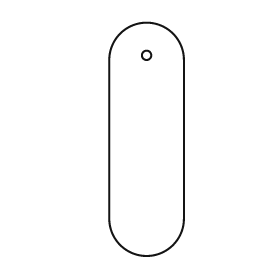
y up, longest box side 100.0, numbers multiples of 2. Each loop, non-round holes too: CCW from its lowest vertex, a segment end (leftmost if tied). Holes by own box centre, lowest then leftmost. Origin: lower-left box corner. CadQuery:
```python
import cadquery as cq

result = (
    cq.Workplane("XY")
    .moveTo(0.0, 16.0)
    .threePointArc((16.0, 0.0), (32.0, 16.0))
    .lineTo(32.0, 84.0)
    .threePointArc((16.0, 100.0), (0.0, 84.0))
    .close()
    .moveTo(16.0, 86.0)
    .circle(2.0)
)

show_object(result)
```